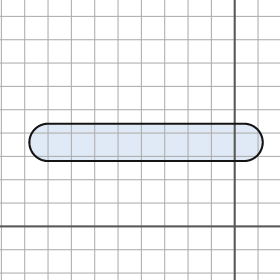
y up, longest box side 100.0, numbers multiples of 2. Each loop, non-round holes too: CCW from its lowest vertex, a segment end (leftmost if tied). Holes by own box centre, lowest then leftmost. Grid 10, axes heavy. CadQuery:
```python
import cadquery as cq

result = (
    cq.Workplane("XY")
    .moveTo(-80.0, 28.0)
    .lineTo(4.0, 28.0)
    .threePointArc((12.0, 36.0), (4.0, 44.0))
    .lineTo(-80.0, 44.0)
    .threePointArc((-88.0, 36.0), (-80.0, 28.0))
    .close()
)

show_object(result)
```